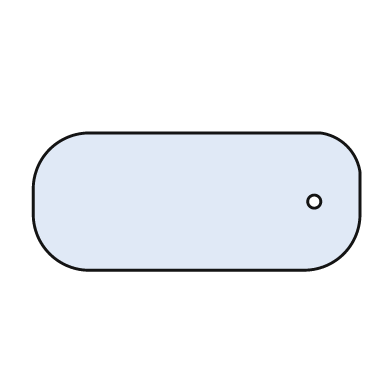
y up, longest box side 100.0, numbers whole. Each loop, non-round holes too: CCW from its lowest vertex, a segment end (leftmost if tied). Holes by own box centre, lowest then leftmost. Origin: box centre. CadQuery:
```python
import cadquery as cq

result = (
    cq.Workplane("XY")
    .moveTo(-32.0, -21.0)
    .lineTo(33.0, -21.0)
    .threePointArc((45.0, -16.0), (50.0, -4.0))
    .lineTo(50.0, 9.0)
    .threePointArc((46.0, 17.0), (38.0, 21.0))
    .lineTo(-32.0, 21.0)
    .threePointArc((-45.0, 16.0), (-50.0, 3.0))
    .lineTo(-50.0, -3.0)
    .threePointArc((-45.0, -16.0), (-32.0, -21.0))
    .close()
    .moveTo(36.0, 0.0)
    .circle(2.0)
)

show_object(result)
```